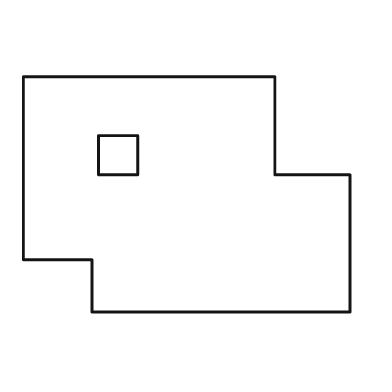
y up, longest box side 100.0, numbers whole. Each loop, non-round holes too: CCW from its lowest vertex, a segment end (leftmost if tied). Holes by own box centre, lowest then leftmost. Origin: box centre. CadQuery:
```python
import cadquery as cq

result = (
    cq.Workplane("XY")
    .moveTo(-29.0, -36.0)
    .lineTo(50.0, -36.0)
    .lineTo(50.0, 6.0)
    .lineTo(27.0, 6.0)
    .lineTo(27.0, 36.0)
    .lineTo(-50.0, 36.0)
    .lineTo(-50.0, -20.0)
    .lineTo(-29.0, -20.0)
    .close()
    .moveTo(-27.0, 6.0)
    .lineTo(-15.0, 6.0)
    .lineTo(-15.0, 18.0)
    .lineTo(-27.0, 18.0)
    .close()
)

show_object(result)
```